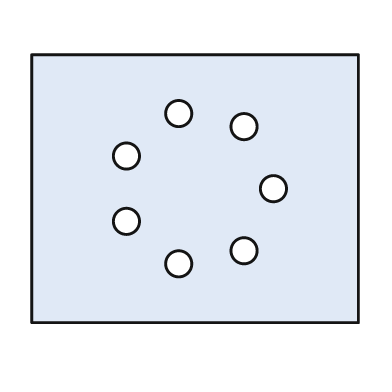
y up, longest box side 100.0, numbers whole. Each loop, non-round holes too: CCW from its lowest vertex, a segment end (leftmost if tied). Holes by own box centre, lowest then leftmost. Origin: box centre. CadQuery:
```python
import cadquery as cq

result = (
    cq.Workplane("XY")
    .moveTo(-50.0, -41.0)
    .lineTo(50.0, -41.0)
    .lineTo(50.0, 41.0)
    .lineTo(-50.0, 41.0)
    .close()
    .moveTo(-5.0, -23.0)
    .circle(4.0)
    .moveTo(15.0, -19.0)
    .circle(4.0)
    .moveTo(-21.0, -10.0)
    .circle(4.0)
    .moveTo(24.0, 0.0)
    .circle(4.0)
    .moveTo(-21.0, 10.0)
    .circle(4.0)
    .moveTo(15.0, 19.0)
    .circle(4.0)
    .moveTo(-5.0, 23.0)
    .circle(4.0)
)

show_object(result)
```